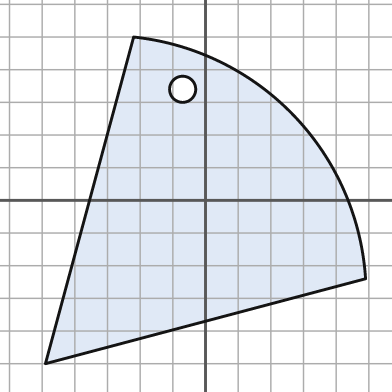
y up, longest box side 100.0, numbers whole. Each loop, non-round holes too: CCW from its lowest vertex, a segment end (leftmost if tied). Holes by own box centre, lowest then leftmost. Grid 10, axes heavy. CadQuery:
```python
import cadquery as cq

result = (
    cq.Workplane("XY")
    .moveTo(-49.0, -50.0)
    .lineTo(49.0, -24.0)
    .threePointArc((27.0, 26.0), (-22.0, 50.0))
    .close()
    .moveTo(-7.0, 34.0)
    .circle(4.0)
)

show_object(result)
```